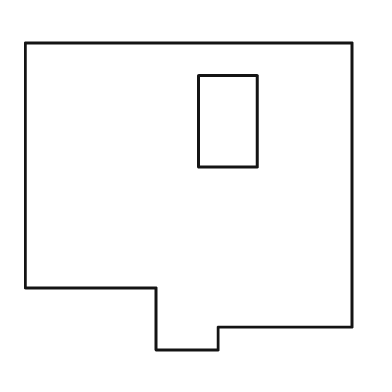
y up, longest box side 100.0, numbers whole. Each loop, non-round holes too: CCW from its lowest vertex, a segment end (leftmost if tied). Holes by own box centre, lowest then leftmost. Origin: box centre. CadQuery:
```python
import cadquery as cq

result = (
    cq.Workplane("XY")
    .moveTo(-10.0, -47.0)
    .lineTo(9.0, -47.0)
    .lineTo(9.0, -40.0)
    .lineTo(50.0, -40.0)
    .lineTo(50.0, 47.0)
    .lineTo(-50.0, 47.0)
    .lineTo(-50.0, -28.0)
    .lineTo(-10.0, -28.0)
    .close()
    .moveTo(3.0, 9.0)
    .lineTo(21.0, 9.0)
    .lineTo(21.0, 37.0)
    .lineTo(3.0, 37.0)
    .close()
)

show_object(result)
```